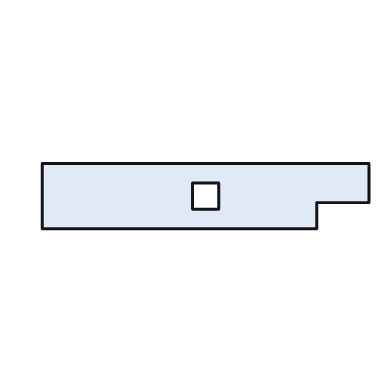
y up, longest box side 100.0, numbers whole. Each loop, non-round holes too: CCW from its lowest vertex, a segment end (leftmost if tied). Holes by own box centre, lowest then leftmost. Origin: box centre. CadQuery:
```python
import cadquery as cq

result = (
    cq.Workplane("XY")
    .moveTo(-50.0, -10.0)
    .lineTo(34.0, -10.0)
    .lineTo(34.0, -2.0)
    .lineTo(50.0, -2.0)
    .lineTo(50.0, 10.0)
    .lineTo(-50.0, 10.0)
    .close()
    .moveTo(-4.0, -4.0)
    .lineTo(4.0, -4.0)
    .lineTo(4.0, 4.0)
    .lineTo(-4.0, 4.0)
    .close()
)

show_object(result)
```